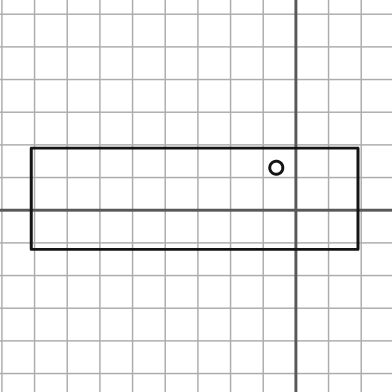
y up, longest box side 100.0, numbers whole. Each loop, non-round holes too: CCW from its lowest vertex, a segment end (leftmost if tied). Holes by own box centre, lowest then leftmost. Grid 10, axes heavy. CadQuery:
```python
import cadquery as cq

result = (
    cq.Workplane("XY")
    .moveTo(-81.0, -12.0)
    .lineTo(19.0, -12.0)
    .lineTo(19.0, 19.0)
    .lineTo(-81.0, 19.0)
    .close()
    .moveTo(-6.0, 13.0)
    .circle(2.0)
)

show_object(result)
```